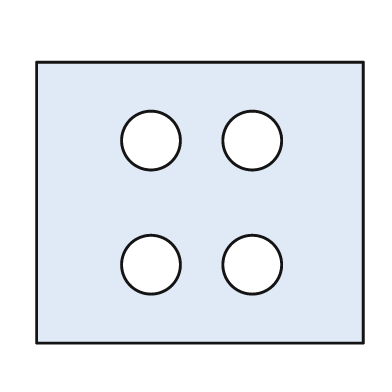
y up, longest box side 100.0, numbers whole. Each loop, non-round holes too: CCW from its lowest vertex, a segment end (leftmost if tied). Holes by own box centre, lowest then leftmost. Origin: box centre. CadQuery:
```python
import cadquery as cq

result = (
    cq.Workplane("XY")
    .moveTo(-50.0, -43.0)
    .lineTo(50.0, -43.0)
    .lineTo(50.0, 43.0)
    .lineTo(-50.0, 43.0)
    .close()
    .moveTo(-15.0, -19.0)
    .circle(9.0)
    .moveTo(16.0, -19.0)
    .circle(9.0)
    .moveTo(-15.0, 19.0)
    .circle(9.0)
    .moveTo(16.0, 19.0)
    .circle(9.0)
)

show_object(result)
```